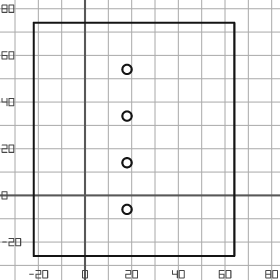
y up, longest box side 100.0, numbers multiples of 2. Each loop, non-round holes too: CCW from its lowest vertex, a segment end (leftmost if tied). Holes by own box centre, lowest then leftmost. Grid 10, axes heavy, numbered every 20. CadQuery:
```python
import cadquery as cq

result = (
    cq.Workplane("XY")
    .moveTo(-22.0, -26.0)
    .lineTo(64.0, -26.0)
    .lineTo(64.0, 74.0)
    .lineTo(-22.0, 74.0)
    .close()
    .moveTo(18.0, -6.0)
    .circle(2.0)
    .moveTo(18.0, 14.0)
    .circle(2.0)
    .moveTo(18.0, 34.0)
    .circle(2.0)
    .moveTo(18.0, 54.0)
    .circle(2.0)
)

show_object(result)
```